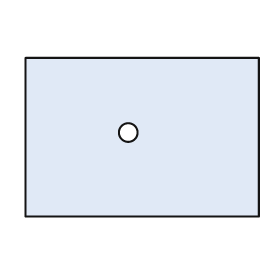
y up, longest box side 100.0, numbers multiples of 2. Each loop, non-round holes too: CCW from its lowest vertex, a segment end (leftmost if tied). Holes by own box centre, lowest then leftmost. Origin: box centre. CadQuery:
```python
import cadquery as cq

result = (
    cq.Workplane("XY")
    .moveTo(-50.0, -34.0)
    .lineTo(50.0, -34.0)
    .lineTo(50.0, 34.0)
    .lineTo(-50.0, 34.0)
    .close()
    .moveTo(-6.0, 2.0)
    .circle(4.0)
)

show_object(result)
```